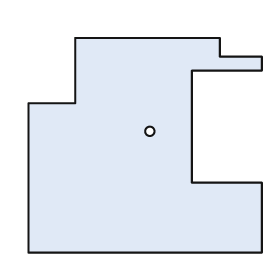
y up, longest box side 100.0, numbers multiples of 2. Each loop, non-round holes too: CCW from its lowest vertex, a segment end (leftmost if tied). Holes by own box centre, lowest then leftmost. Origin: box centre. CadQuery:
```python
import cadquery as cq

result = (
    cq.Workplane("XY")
    .moveTo(-50.0, -46.0)
    .lineTo(50.0, -46.0)
    .lineTo(50.0, -16.0)
    .lineTo(20.0, -16.0)
    .lineTo(20.0, 32.0)
    .lineTo(50.0, 32.0)
    .lineTo(50.0, 38.0)
    .lineTo(32.0, 38.0)
    .lineTo(32.0, 46.0)
    .lineTo(-30.0, 46.0)
    .lineTo(-30.0, 18.0)
    .lineTo(-50.0, 18.0)
    .close()
    .moveTo(2.0, 6.0)
    .circle(2.0)
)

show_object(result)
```